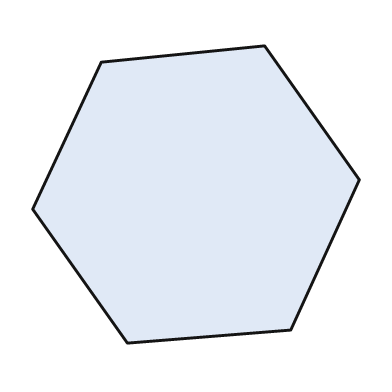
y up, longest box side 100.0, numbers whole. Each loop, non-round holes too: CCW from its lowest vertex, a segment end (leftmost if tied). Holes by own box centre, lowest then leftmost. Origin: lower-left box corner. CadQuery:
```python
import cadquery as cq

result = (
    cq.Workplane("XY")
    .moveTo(29.0, 0.0)
    .lineTo(79.0, 4.0)
    .lineTo(100.0, 50.0)
    .lineTo(71.0, 91.0)
    .lineTo(21.0, 86.0)
    .lineTo(0.0, 41.0)
    .close()
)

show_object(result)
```